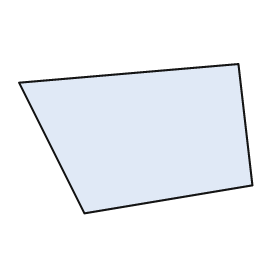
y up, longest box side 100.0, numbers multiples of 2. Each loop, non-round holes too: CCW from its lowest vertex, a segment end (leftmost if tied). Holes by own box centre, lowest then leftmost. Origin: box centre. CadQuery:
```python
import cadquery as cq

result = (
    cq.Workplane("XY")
    .moveTo(-22.0, -32.0)
    .lineTo(50.0, -20.0)
    .lineTo(44.0, 32.0)
    .lineTo(-50.0, 24.0)
    .close()
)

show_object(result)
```